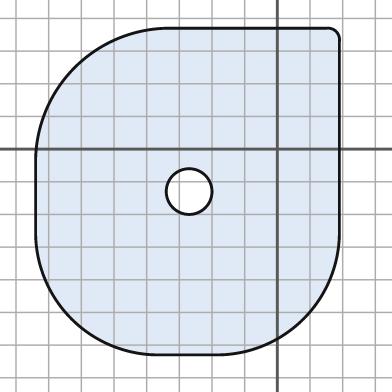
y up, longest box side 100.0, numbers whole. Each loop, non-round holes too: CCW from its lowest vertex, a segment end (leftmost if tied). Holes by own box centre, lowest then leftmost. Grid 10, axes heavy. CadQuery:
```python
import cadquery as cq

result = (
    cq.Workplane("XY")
    .moveTo(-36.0, -63.0)
    .lineTo(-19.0, -63.0)
    .threePointArc((8.0, -52.0), (19.0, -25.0))
    .lineTo(19.0, 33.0)
    .threePointArc((18.0, 36.0), (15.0, 37.0))
    .lineTo(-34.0, 37.0)
    .threePointArc((-62.0, 25.0), (-74.0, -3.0))
    .lineTo(-74.0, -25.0)
    .threePointArc((-63.0, -52.0), (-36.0, -63.0))
    .close()
    .moveTo(-27.0, -13.0)
    .circle(7.0)
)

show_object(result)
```